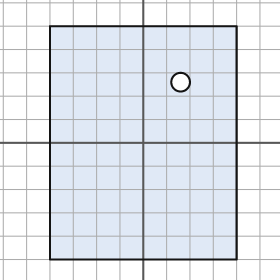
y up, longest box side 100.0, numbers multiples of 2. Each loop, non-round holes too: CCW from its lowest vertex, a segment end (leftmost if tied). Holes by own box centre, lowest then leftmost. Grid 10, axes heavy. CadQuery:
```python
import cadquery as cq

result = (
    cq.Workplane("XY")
    .moveTo(-40.0, -50.0)
    .lineTo(40.0, -50.0)
    .lineTo(40.0, 50.0)
    .lineTo(-40.0, 50.0)
    .close()
    .moveTo(16.0, 26.0)
    .circle(4.0)
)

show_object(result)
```